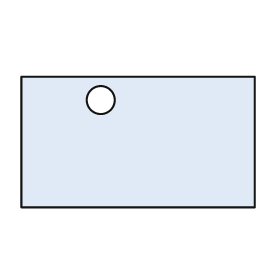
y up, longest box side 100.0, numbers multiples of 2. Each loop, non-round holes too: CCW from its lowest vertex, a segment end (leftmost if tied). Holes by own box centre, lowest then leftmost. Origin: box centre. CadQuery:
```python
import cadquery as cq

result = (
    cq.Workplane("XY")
    .moveTo(-50.0, -28.0)
    .lineTo(50.0, -28.0)
    .lineTo(50.0, 28.0)
    .lineTo(-50.0, 28.0)
    .close()
    .moveTo(-16.0, 18.0)
    .circle(6.0)
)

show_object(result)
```